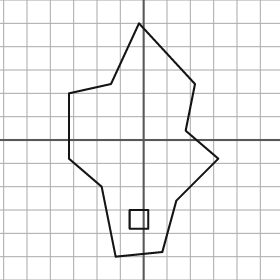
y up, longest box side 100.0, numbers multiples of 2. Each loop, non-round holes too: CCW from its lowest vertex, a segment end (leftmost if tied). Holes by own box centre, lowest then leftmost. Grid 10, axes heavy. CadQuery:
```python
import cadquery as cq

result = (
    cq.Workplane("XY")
    .moveTo(-12.0, -50.0)
    .lineTo(8.0, -48.0)
    .lineTo(14.0, -26.0)
    .lineTo(32.0, -8.0)
    .lineTo(18.0, 4.0)
    .lineTo(22.0, 24.0)
    .lineTo(-2.0, 50.0)
    .lineTo(-14.0, 24.0)
    .lineTo(-32.0, 20.0)
    .lineTo(-32.0, -8.0)
    .lineTo(-18.0, -20.0)
    .close()
    .moveTo(-6.0, -38.0)
    .lineTo(2.0, -38.0)
    .lineTo(2.0, -30.0)
    .lineTo(-6.0, -30.0)
    .close()
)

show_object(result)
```